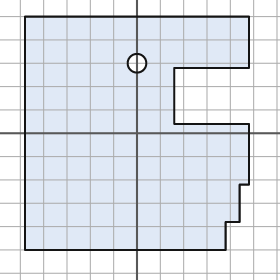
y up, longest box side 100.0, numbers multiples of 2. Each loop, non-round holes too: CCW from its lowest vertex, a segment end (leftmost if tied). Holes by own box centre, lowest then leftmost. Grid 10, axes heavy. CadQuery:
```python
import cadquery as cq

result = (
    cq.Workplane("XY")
    .moveTo(-48.0, -50.0)
    .lineTo(38.0, -50.0)
    .lineTo(38.0, -38.0)
    .lineTo(44.0, -38.0)
    .lineTo(44.0, -22.0)
    .lineTo(48.0, -22.0)
    .lineTo(48.0, 4.0)
    .lineTo(16.0, 4.0)
    .lineTo(16.0, 28.0)
    .lineTo(48.0, 28.0)
    .lineTo(48.0, 50.0)
    .lineTo(-48.0, 50.0)
    .close()
    .moveTo(0.0, 30.0)
    .circle(4.0)
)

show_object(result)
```